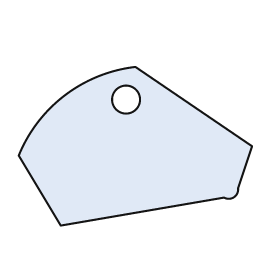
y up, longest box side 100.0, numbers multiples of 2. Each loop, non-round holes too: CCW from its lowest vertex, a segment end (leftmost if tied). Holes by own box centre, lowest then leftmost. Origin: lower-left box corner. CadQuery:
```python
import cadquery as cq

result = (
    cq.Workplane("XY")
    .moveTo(18.0, 0.0)
    .lineTo(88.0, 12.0)
    .threePointArc((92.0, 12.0), (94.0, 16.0))
    .lineTo(100.0, 34.0)
    .lineTo(50.0, 68.0)
    .threePointArc((20.0, 56.0), (0.0, 30.0))
    .close()
    .moveTo(46.0, 54.0)
    .circle(6.0)
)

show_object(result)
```